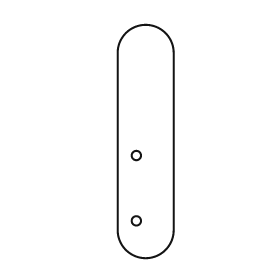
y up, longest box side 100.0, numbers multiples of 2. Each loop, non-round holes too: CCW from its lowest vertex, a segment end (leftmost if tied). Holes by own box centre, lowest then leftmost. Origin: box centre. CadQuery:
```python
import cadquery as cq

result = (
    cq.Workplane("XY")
    .moveTo(-12.0, -38.0)
    .threePointArc((0.0, -50.0), (12.0, -38.0))
    .lineTo(12.0, 38.0)
    .threePointArc((0.0, 50.0), (-12.0, 38.0))
    .close()
    .moveTo(-4.0, -34.0)
    .circle(2.0)
    .moveTo(-4.0, -6.0)
    .circle(2.0)
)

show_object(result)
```